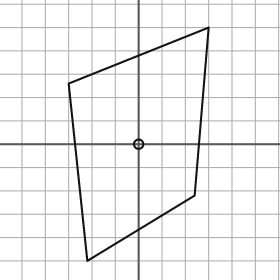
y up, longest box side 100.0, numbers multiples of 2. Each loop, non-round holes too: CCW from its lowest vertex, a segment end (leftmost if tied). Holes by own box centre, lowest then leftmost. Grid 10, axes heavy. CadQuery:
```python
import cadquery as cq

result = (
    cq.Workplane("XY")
    .moveTo(-22.0, -50.0)
    .lineTo(24.0, -22.0)
    .lineTo(30.0, 50.0)
    .lineTo(-30.0, 26.0)
    .close()
    .moveTo(0.0, 0.0)
    .circle(2.0)
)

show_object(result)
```